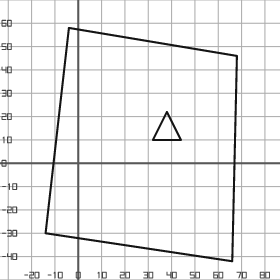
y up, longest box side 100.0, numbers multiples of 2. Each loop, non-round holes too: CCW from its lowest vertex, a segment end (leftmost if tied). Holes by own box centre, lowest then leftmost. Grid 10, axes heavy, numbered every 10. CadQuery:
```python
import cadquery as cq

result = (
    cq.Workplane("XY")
    .moveTo(66.0, -42.0)
    .lineTo(68.0, 46.0)
    .lineTo(-4.0, 58.0)
    .lineTo(-14.0, -30.0)
    .close()
    .moveTo(32.0, 10.0)
    .lineTo(44.0, 10.0)
    .lineTo(38.0, 22.0)
    .close()
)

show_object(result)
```